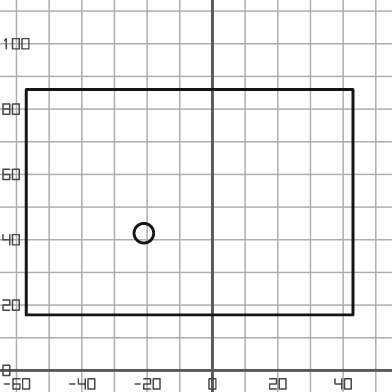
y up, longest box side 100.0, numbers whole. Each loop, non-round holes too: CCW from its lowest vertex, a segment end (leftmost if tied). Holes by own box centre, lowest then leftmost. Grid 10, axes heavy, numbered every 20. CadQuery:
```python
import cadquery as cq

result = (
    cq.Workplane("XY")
    .moveTo(-57.0, 17.0)
    .lineTo(43.0, 17.0)
    .lineTo(43.0, 86.0)
    .lineTo(-57.0, 86.0)
    .close()
    .moveTo(-21.0, 42.0)
    .circle(3.0)
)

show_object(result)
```